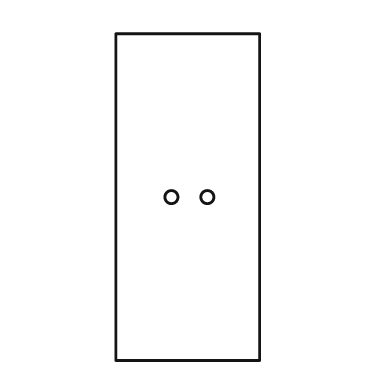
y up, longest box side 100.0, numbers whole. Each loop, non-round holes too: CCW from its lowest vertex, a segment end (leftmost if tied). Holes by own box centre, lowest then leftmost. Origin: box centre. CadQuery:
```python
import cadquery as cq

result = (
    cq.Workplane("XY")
    .moveTo(-22.0, -50.0)
    .lineTo(22.0, -50.0)
    .lineTo(22.0, 50.0)
    .lineTo(-22.0, 50.0)
    .close()
    .moveTo(-5.0, 0.0)
    .circle(2.0)
    .moveTo(6.0, 0.0)
    .circle(2.0)
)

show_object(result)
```